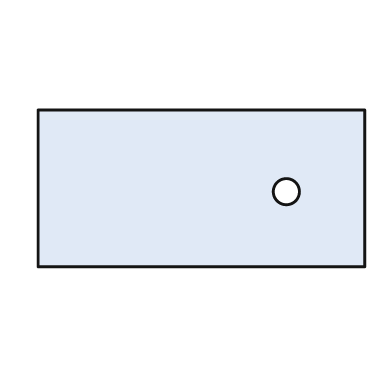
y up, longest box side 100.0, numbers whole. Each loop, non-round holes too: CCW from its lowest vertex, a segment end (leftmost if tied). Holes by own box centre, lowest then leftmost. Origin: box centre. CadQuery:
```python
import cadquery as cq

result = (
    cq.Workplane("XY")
    .moveTo(-50.0, -24.0)
    .lineTo(50.0, -24.0)
    .lineTo(50.0, 24.0)
    .lineTo(-50.0, 24.0)
    .close()
    .moveTo(26.0, -1.0)
    .circle(4.0)
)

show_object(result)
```